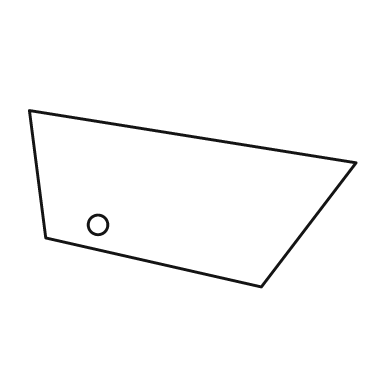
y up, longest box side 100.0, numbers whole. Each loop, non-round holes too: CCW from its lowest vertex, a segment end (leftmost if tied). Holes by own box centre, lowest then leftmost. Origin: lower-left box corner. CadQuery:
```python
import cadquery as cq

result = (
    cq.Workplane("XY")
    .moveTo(71.0, 0.0)
    .lineTo(100.0, 38.0)
    .lineTo(0.0, 54.0)
    .lineTo(5.0, 15.0)
    .close()
    .moveTo(21.0, 19.0)
    .circle(3.0)
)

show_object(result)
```